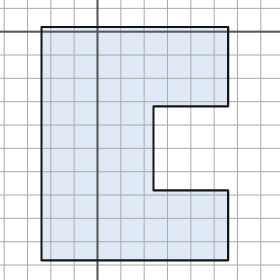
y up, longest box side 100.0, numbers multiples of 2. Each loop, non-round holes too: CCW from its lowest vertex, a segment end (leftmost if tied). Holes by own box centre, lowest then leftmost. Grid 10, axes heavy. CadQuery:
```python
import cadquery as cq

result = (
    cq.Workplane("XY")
    .moveTo(-24.0, -98.0)
    .lineTo(56.0, -98.0)
    .lineTo(56.0, -68.0)
    .lineTo(24.0, -68.0)
    .lineTo(24.0, -32.0)
    .lineTo(56.0, -32.0)
    .lineTo(56.0, 2.0)
    .lineTo(-24.0, 2.0)
    .close()
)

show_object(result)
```